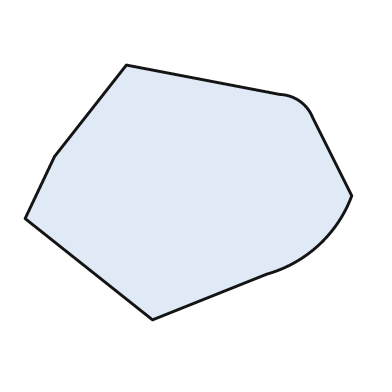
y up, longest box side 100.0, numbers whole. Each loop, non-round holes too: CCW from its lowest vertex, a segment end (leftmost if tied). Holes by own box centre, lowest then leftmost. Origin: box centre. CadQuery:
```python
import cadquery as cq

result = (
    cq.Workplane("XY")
    .moveTo(-11.0, -39.0)
    .lineTo(24.0, -25.0)
    .threePointArc((40.0, -16.0), (50.0, -1.0))
    .lineTo(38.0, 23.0)
    .threePointArc((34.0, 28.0), (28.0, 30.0))
    .lineTo(-19.0, 39.0)
    .lineTo(-41.0, 11.0)
    .lineTo(-50.0, -8.0)
    .close()
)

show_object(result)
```